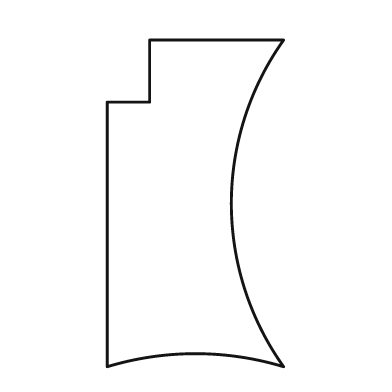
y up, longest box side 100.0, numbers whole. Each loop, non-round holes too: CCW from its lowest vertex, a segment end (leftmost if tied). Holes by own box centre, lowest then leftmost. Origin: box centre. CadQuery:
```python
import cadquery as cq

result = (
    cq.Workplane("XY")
    .moveTo(-27.0, -50.0)
    .threePointArc((0.0, -46.0), (27.0, -50.0))
    .threePointArc((11.0, 0.0), (27.0, 50.0))
    .lineTo(-14.0, 50.0)
    .lineTo(-14.0, 31.0)
    .lineTo(-27.0, 31.0)
    .close()
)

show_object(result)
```